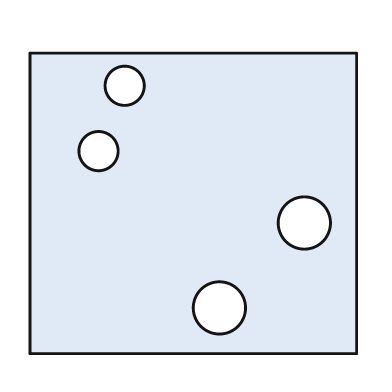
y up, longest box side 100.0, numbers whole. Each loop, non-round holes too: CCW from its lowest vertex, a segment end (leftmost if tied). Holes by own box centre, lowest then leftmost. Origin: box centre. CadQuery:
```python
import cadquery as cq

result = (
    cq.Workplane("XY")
    .moveTo(-50.0, -46.0)
    .lineTo(50.0, -46.0)
    .lineTo(50.0, 46.0)
    .lineTo(-50.0, 46.0)
    .close()
    .moveTo(8.0, -32.0)
    .circle(8.0)
    .moveTo(34.0, -6.0)
    .circle(8.0)
    .moveTo(-29.0, 16.0)
    .circle(6.0)
    .moveTo(-21.0, 36.0)
    .circle(6.0)
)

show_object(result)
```